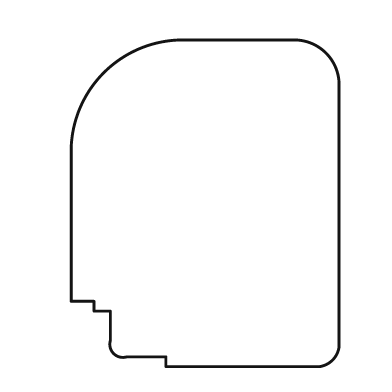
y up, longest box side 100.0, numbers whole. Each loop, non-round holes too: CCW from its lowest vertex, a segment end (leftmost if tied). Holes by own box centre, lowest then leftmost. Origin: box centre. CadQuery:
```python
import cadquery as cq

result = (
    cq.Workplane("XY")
    .moveTo(-12.0, -50.0)
    .lineTo(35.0, -50.0)
    .threePointArc((39.0, -48.0), (41.0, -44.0))
    .lineTo(41.0, 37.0)
    .threePointArc((37.0, 46.0), (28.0, 50.0))
    .lineTo(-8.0, 50.0)
    .threePointArc((-31.0, 40.0), (-41.0, 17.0))
    .lineTo(-41.0, -30.0)
    .lineTo(-34.0, -30.0)
    .lineTo(-34.0, -33.0)
    .lineTo(-29.0, -33.0)
    .lineTo(-29.0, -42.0)
    .threePointArc((-28.0, -46.0), (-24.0, -47.0))
    .lineTo(-12.0, -47.0)
    .close()
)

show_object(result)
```